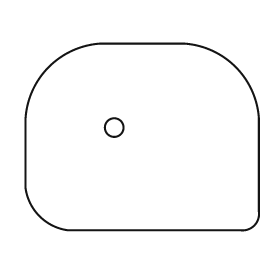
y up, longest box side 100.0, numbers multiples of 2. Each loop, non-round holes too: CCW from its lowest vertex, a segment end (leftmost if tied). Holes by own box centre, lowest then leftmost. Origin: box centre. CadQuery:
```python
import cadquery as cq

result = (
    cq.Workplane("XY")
    .moveTo(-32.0, -40.0)
    .lineTo(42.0, -40.0)
    .threePointArc((48.0, -38.0), (50.0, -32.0))
    .lineTo(50.0, 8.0)
    .threePointArc((40.0, 30.0), (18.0, 40.0))
    .lineTo(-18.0, 40.0)
    .threePointArc((-40.0, 30.0), (-50.0, 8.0))
    .lineTo(-50.0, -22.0)
    .threePointArc((-44.0, -34.0), (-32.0, -40.0))
    .close()
    .moveTo(-12.0, 4.0)
    .circle(4.0)
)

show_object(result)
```